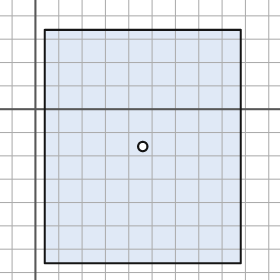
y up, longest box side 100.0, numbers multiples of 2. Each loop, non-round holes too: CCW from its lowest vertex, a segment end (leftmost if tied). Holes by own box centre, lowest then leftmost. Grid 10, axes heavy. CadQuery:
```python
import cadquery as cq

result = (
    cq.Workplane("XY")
    .moveTo(4.0, -66.0)
    .lineTo(88.0, -66.0)
    .lineTo(88.0, 34.0)
    .lineTo(4.0, 34.0)
    .close()
    .moveTo(46.0, -16.0)
    .circle(2.0)
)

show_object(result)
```